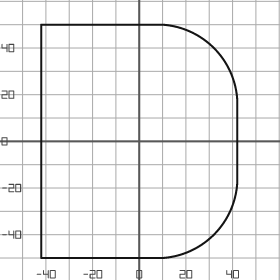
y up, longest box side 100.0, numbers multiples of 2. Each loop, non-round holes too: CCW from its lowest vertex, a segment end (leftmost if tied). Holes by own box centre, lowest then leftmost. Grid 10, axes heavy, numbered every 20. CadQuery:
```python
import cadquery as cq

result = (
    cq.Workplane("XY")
    .moveTo(-42.0, -50.0)
    .lineTo(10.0, -50.0)
    .threePointArc((32.0, -40.0), (42.0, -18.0))
    .lineTo(42.0, 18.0)
    .threePointArc((32.0, 40.0), (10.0, 50.0))
    .lineTo(-42.0, 50.0)
    .close()
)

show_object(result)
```